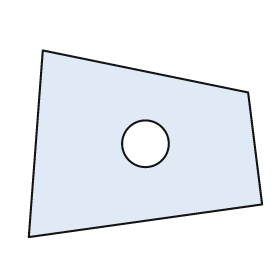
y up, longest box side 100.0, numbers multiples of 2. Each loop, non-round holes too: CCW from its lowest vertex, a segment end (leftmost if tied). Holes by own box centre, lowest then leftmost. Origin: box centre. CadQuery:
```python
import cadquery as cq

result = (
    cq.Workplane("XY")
    .moveTo(-50.0, -40.0)
    .lineTo(50.0, -26.0)
    .lineTo(44.0, 22.0)
    .lineTo(-44.0, 40.0)
    .close()
    .moveTo(0.0, 0.0)
    .circle(10.0)
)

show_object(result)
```